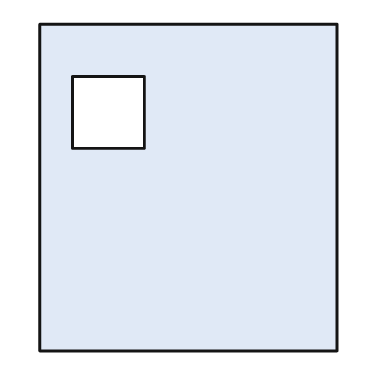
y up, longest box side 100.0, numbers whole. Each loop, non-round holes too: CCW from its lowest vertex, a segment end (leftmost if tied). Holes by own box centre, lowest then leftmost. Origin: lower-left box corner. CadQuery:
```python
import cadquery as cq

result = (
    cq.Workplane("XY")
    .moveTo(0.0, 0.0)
    .lineTo(91.0, 0.0)
    .lineTo(91.0, 100.0)
    .lineTo(0.0, 100.0)
    .close()
    .moveTo(10.0, 62.0)
    .lineTo(32.0, 62.0)
    .lineTo(32.0, 84.0)
    .lineTo(10.0, 84.0)
    .close()
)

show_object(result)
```